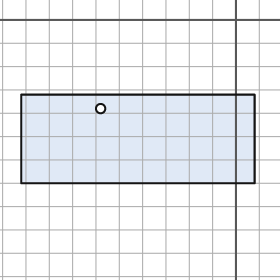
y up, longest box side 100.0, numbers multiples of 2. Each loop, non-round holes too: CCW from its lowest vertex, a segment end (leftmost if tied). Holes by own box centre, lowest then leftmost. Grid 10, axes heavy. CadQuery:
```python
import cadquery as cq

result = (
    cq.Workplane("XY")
    .moveTo(-92.0, -70.0)
    .lineTo(8.0, -70.0)
    .lineTo(8.0, -32.0)
    .lineTo(-92.0, -32.0)
    .close()
    .moveTo(-58.0, -38.0)
    .circle(2.0)
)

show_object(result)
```